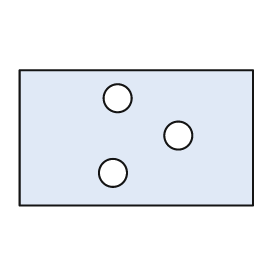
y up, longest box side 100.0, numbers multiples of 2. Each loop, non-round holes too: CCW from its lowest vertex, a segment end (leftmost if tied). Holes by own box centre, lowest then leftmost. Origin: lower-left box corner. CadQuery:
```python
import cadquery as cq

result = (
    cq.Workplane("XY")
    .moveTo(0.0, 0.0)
    .lineTo(100.0, 0.0)
    .lineTo(100.0, 58.0)
    .lineTo(0.0, 58.0)
    .close()
    .moveTo(40.0, 14.0)
    .circle(6.0)
    .moveTo(68.0, 30.0)
    .circle(6.0)
    .moveTo(42.0, 46.0)
    .circle(6.0)
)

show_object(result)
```